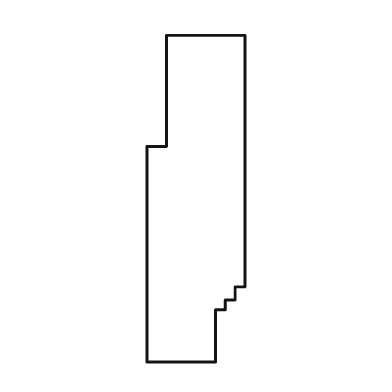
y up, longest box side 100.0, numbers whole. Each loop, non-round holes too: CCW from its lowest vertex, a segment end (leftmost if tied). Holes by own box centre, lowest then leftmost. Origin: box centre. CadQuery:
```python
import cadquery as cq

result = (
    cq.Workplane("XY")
    .moveTo(-15.0, -50.0)
    .lineTo(6.0, -50.0)
    .lineTo(6.0, -34.0)
    .lineTo(9.0, -34.0)
    .lineTo(9.0, -31.0)
    .lineTo(12.0, -31.0)
    .lineTo(12.0, -27.0)
    .lineTo(15.0, -27.0)
    .lineTo(15.0, 50.0)
    .lineTo(-9.0, 50.0)
    .lineTo(-9.0, 16.0)
    .lineTo(-15.0, 16.0)
    .close()
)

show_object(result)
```